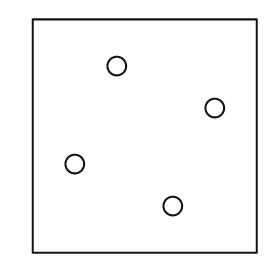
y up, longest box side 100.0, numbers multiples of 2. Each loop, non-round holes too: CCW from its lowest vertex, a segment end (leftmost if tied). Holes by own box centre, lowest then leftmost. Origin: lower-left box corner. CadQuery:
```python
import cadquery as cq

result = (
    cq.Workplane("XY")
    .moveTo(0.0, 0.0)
    .lineTo(96.0, 0.0)
    .lineTo(96.0, 100.0)
    .lineTo(0.0, 100.0)
    .close()
    .moveTo(60.0, 20.0)
    .circle(4.0)
    .moveTo(18.0, 38.0)
    .circle(4.0)
    .moveTo(78.0, 62.0)
    .circle(4.0)
    .moveTo(36.0, 80.0)
    .circle(4.0)
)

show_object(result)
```